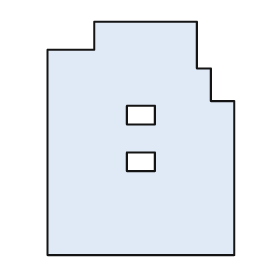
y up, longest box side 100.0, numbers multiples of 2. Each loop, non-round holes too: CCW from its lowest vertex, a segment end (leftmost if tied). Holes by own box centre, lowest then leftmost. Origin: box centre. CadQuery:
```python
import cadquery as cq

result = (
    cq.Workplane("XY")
    .moveTo(-40.0, -50.0)
    .lineTo(40.0, -50.0)
    .lineTo(40.0, 16.0)
    .lineTo(30.0, 16.0)
    .lineTo(30.0, 30.0)
    .lineTo(24.0, 30.0)
    .lineTo(24.0, 50.0)
    .lineTo(-20.0, 50.0)
    .lineTo(-20.0, 38.0)
    .lineTo(-40.0, 38.0)
    .close()
    .moveTo(-6.0, -14.0)
    .lineTo(6.0, -14.0)
    .lineTo(6.0, -6.0)
    .lineTo(-6.0, -6.0)
    .close()
    .moveTo(-6.0, 6.0)
    .lineTo(6.0, 6.0)
    .lineTo(6.0, 14.0)
    .lineTo(-6.0, 14.0)
    .close()
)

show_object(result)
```